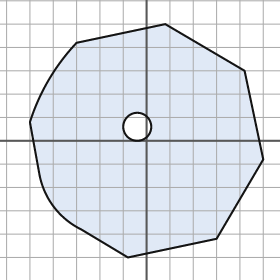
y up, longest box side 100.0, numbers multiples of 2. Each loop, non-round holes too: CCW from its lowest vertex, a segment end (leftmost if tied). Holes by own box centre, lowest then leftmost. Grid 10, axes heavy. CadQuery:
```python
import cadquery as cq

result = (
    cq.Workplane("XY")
    .moveTo(-8.0, -50.0)
    .lineTo(30.0, -42.0)
    .lineTo(50.0, -8.0)
    .lineTo(42.0, 30.0)
    .lineTo(8.0, 50.0)
    .lineTo(-30.0, 42.0)
    .threePointArc((-42.0, 26.0), (-50.0, 8.0))
    .lineTo(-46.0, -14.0)
    .threePointArc((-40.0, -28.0), (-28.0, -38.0))
    .close()
    .moveTo(-4.0, 6.0)
    .circle(6.0)
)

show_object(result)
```